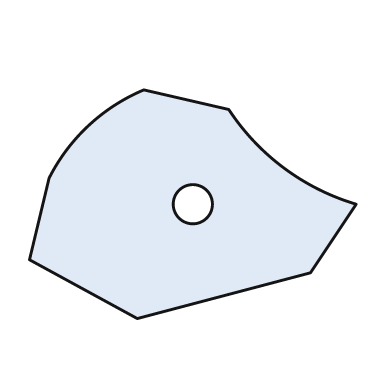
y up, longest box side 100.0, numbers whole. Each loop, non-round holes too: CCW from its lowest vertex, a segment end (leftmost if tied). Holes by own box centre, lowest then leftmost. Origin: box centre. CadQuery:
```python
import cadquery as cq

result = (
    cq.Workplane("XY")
    .moveTo(-17.0, -35.0)
    .lineTo(36.0, -21.0)
    .lineTo(50.0, 0.0)
    .threePointArc((28.0, 11.0), (11.0, 29.0))
    .lineTo(-15.0, 35.0)
    .threePointArc((-32.0, 24.0), (-44.0, 8.0))
    .lineTo(-50.0, -17.0)
    .close()
    .moveTo(0.0, 0.0)
    .circle(6.0)
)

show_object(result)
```